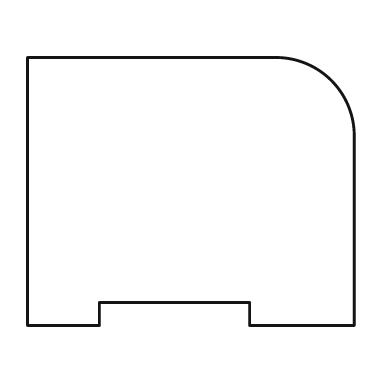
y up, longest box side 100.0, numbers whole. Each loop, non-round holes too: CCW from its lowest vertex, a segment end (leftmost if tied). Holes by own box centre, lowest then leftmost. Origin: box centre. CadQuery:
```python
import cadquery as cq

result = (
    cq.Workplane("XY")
    .moveTo(-50.0, -41.0)
    .lineTo(-28.0, -41.0)
    .lineTo(-28.0, -34.0)
    .lineTo(18.0, -34.0)
    .lineTo(18.0, -41.0)
    .lineTo(50.0, -41.0)
    .lineTo(50.0, 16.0)
    .threePointArc((43.0, 34.0), (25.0, 41.0))
    .lineTo(-50.0, 41.0)
    .close()
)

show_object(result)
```